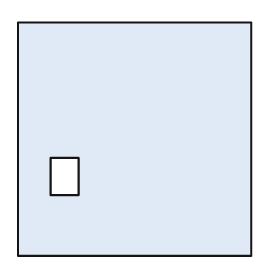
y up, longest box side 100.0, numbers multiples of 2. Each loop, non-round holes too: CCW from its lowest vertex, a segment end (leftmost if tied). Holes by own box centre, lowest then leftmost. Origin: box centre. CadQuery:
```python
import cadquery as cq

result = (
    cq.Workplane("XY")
    .moveTo(-50.0, -50.0)
    .lineTo(50.0, -50.0)
    .lineTo(50.0, 50.0)
    .lineTo(-50.0, 50.0)
    .close()
    .moveTo(-36.0, -24.0)
    .lineTo(-24.0, -24.0)
    .lineTo(-24.0, -8.0)
    .lineTo(-36.0, -8.0)
    .close()
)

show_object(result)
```